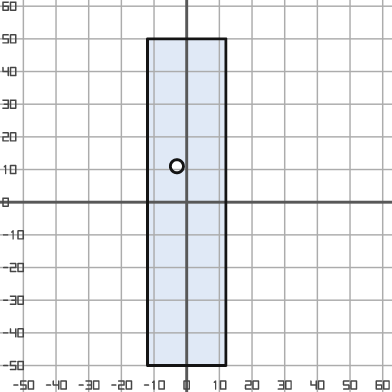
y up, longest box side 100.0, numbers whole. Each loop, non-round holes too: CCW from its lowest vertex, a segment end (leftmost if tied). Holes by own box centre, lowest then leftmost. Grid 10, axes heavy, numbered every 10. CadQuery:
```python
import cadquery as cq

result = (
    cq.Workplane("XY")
    .moveTo(-12.0, -50.0)
    .lineTo(12.0, -50.0)
    .lineTo(12.0, 50.0)
    .lineTo(-12.0, 50.0)
    .close()
    .moveTo(-3.0, 11.0)
    .circle(2.0)
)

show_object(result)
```